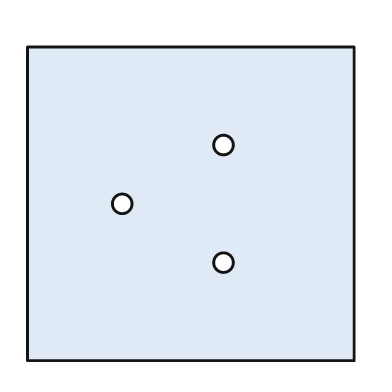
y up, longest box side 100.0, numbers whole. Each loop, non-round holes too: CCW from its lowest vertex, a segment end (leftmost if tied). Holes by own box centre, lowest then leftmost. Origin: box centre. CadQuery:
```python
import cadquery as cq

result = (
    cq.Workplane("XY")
    .moveTo(-50.0, -48.0)
    .lineTo(50.0, -48.0)
    .lineTo(50.0, 48.0)
    .lineTo(-50.0, 48.0)
    .close()
    .moveTo(10.0, -18.0)
    .circle(3.0)
    .moveTo(-21.0, 0.0)
    .circle(3.0)
    .moveTo(10.0, 18.0)
    .circle(3.0)
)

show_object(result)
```